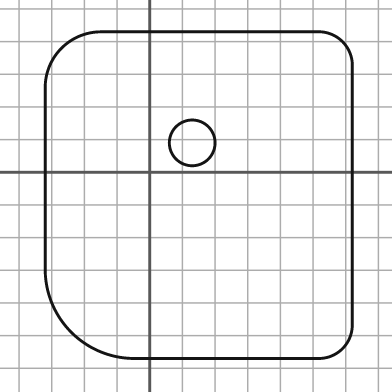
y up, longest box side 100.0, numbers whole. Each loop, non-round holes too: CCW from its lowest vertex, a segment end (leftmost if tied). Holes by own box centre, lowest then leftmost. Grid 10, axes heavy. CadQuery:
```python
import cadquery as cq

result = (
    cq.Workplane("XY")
    .moveTo(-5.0, -57.0)
    .lineTo(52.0, -57.0)
    .threePointArc((59.0, -54.0), (62.0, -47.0))
    .lineTo(62.0, 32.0)
    .threePointArc((59.0, 40.0), (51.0, 43.0))
    .lineTo(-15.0, 43.0)
    .threePointArc((-27.0, 38.0), (-32.0, 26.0))
    .lineTo(-32.0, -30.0)
    .threePointArc((-24.0, -49.0), (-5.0, -57.0))
    .close()
    .moveTo(13.0, 9.0)
    .circle(7.0)
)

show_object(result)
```